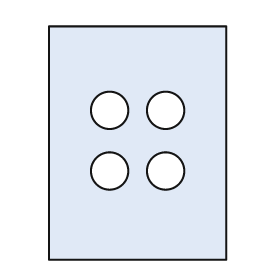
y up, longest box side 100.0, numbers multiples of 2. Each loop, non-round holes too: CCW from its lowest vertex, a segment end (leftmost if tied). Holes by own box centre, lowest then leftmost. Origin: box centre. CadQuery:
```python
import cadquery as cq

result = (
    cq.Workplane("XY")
    .moveTo(-38.0, -50.0)
    .lineTo(38.0, -50.0)
    .lineTo(38.0, 50.0)
    .lineTo(-38.0, 50.0)
    .close()
    .moveTo(-12.0, -12.0)
    .circle(8.0)
    .moveTo(12.0, -12.0)
    .circle(8.0)
    .moveTo(-12.0, 14.0)
    .circle(8.0)
    .moveTo(12.0, 14.0)
    .circle(8.0)
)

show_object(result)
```